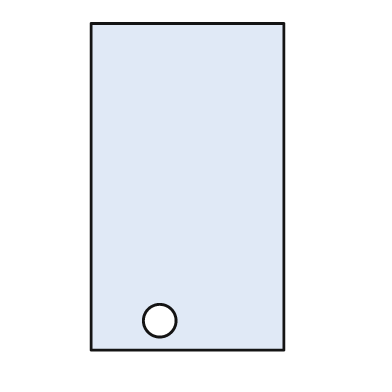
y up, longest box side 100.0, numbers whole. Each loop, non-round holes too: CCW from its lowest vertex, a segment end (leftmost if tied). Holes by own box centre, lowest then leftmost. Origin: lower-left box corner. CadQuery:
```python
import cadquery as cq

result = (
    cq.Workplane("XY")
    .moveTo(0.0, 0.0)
    .lineTo(59.0, 0.0)
    .lineTo(59.0, 100.0)
    .lineTo(0.0, 100.0)
    .close()
    .moveTo(21.0, 9.0)
    .circle(5.0)
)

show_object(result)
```